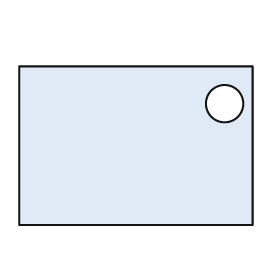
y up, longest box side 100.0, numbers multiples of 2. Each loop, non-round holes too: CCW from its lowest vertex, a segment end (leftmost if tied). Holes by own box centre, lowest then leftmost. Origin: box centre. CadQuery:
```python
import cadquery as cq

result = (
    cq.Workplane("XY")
    .moveTo(-50.0, -34.0)
    .lineTo(50.0, -34.0)
    .lineTo(50.0, 34.0)
    .lineTo(-50.0, 34.0)
    .close()
    .moveTo(38.0, 18.0)
    .circle(8.0)
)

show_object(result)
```